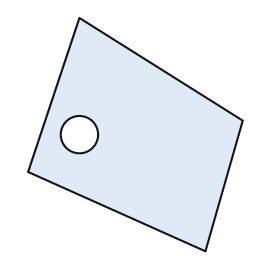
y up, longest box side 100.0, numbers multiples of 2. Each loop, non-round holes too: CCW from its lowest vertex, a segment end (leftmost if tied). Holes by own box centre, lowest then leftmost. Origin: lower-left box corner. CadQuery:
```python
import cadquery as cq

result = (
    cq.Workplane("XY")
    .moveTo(76.0, 0.0)
    .lineTo(92.0, 56.0)
    .lineTo(22.0, 100.0)
    .lineTo(0.0, 34.0)
    .close()
    .moveTo(22.0, 50.0)
    .circle(8.0)
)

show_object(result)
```